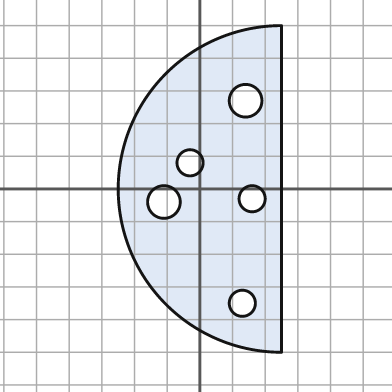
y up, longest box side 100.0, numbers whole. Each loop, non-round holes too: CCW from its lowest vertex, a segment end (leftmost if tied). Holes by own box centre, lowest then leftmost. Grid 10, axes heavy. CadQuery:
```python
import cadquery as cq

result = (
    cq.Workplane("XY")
    .moveTo(25.0, -50.0)
    .lineTo(25.0, 50.0)
    .threePointArc((-25.0, 0.0), (25.0, -50.0))
    .close()
    .moveTo(13.0, -35.0)
    .circle(4.0)
    .moveTo(-11.0, -4.0)
    .circle(5.0)
    .moveTo(16.0, -3.0)
    .circle(4.0)
    .moveTo(-3.0, 8.0)
    .circle(4.0)
    .moveTo(14.0, 27.0)
    .circle(5.0)
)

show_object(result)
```